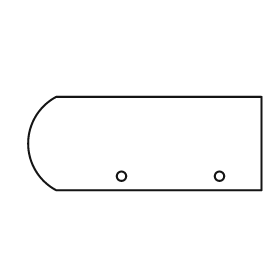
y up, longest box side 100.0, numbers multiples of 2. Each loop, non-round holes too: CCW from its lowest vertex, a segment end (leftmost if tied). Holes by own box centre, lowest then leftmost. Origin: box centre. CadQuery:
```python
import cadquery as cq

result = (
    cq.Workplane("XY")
    .moveTo(-38.0, -20.0)
    .lineTo(50.0, -20.0)
    .lineTo(50.0, 20.0)
    .lineTo(-38.0, 20.0)
    .threePointArc((-50.0, 0.0), (-38.0, -20.0))
    .close()
    .moveTo(-10.0, -14.0)
    .circle(2.0)
    .moveTo(32.0, -14.0)
    .circle(2.0)
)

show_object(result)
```